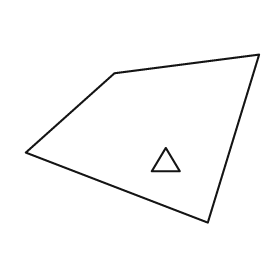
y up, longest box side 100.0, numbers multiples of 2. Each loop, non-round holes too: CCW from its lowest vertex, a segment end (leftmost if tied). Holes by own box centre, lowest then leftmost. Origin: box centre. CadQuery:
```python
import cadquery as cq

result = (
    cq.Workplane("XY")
    .moveTo(28.0, -36.0)
    .lineTo(50.0, 36.0)
    .lineTo(-12.0, 28.0)
    .lineTo(-50.0, -6.0)
    .close()
    .moveTo(4.0, -14.0)
    .lineTo(16.0, -14.0)
    .lineTo(10.0, -4.0)
    .close()
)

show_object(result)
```